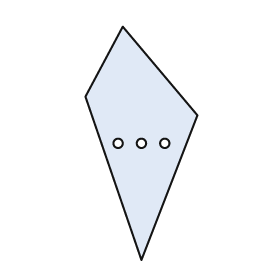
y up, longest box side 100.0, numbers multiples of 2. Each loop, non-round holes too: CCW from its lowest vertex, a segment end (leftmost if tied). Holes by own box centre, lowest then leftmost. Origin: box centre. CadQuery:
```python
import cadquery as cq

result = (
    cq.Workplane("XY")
    .moveTo(0.0, -50.0)
    .lineTo(24.0, 12.0)
    .lineTo(-8.0, 50.0)
    .lineTo(-24.0, 20.0)
    .close()
    .moveTo(-10.0, 0.0)
    .circle(2.0)
    .moveTo(0.0, 0.0)
    .circle(2.0)
    .moveTo(10.0, 0.0)
    .circle(2.0)
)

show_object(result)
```